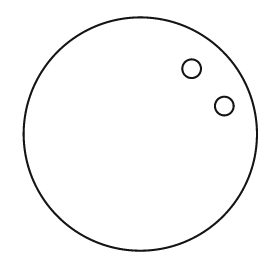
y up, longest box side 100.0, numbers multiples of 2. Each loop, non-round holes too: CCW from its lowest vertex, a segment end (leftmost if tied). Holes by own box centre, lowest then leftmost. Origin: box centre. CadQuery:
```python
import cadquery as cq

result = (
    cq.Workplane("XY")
    .moveTo(0.0, 0.0)
    .circle(50.0)
    .moveTo(36.0, 12.0)
    .circle(4.0)
    .moveTo(22.0, 28.0)
    .circle(4.0)
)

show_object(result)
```